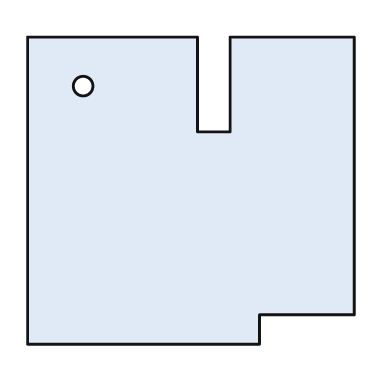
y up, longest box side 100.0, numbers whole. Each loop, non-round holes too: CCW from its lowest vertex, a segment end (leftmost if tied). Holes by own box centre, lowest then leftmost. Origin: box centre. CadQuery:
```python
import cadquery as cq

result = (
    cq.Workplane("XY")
    .moveTo(-50.0, -47.0)
    .lineTo(21.0, -47.0)
    .lineTo(21.0, -38.0)
    .lineTo(50.0, -38.0)
    .lineTo(50.0, 47.0)
    .lineTo(12.0, 47.0)
    .lineTo(12.0, 18.0)
    .lineTo(2.0, 18.0)
    .lineTo(2.0, 47.0)
    .lineTo(-50.0, 47.0)
    .close()
    .moveTo(-33.0, 32.0)
    .circle(3.0)
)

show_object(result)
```